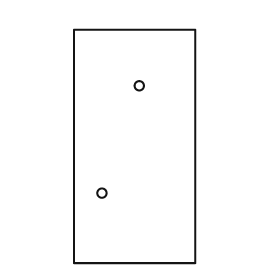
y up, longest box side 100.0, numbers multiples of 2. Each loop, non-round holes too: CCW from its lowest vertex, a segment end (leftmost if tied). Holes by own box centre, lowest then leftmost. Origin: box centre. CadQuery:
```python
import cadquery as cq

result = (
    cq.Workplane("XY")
    .moveTo(-26.0, -50.0)
    .lineTo(26.0, -50.0)
    .lineTo(26.0, 50.0)
    .lineTo(-26.0, 50.0)
    .close()
    .moveTo(-14.0, -20.0)
    .circle(2.0)
    .moveTo(2.0, 26.0)
    .circle(2.0)
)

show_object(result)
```